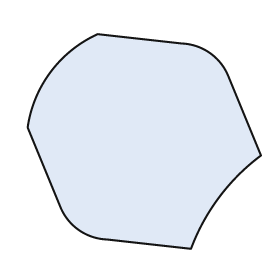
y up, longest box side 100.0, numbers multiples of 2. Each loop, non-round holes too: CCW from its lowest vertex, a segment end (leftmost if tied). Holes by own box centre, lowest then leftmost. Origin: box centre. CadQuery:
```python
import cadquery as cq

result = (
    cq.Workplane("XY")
    .moveTo(20.0, -46.0)
    .threePointArc((32.0, -24.0), (50.0, -6.0))
    .lineTo(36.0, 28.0)
    .threePointArc((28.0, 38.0), (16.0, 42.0))
    .lineTo(-20.0, 46.0)
    .threePointArc((-40.0, 30.0), (-50.0, 6.0))
    .lineTo(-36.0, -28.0)
    .threePointArc((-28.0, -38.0), (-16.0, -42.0))
    .close()
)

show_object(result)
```